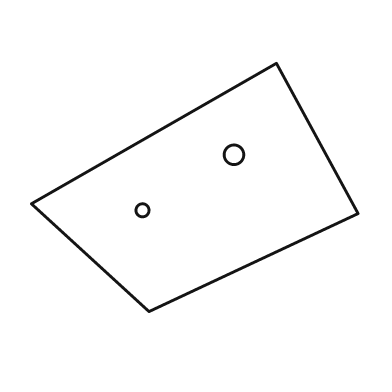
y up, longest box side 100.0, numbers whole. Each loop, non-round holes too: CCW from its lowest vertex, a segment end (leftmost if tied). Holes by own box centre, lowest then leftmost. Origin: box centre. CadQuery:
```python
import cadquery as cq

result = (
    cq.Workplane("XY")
    .moveTo(-14.0, -38.0)
    .lineTo(50.0, -8.0)
    .lineTo(25.0, 38.0)
    .lineTo(-50.0, -5.0)
    .close()
    .moveTo(-16.0, -7.0)
    .circle(2.0)
    .moveTo(12.0, 10.0)
    .circle(3.0)
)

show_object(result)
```